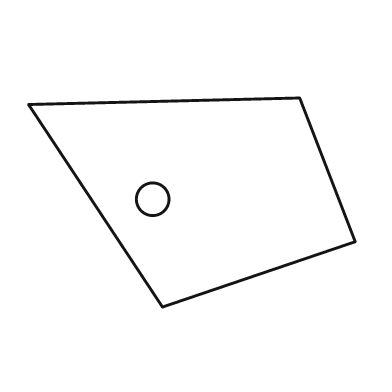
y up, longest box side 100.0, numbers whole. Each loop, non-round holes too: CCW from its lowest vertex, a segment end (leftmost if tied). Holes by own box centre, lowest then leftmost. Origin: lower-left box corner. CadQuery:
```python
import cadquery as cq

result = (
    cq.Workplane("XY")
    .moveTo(41.0, 0.0)
    .lineTo(100.0, 20.0)
    .lineTo(83.0, 64.0)
    .lineTo(0.0, 62.0)
    .close()
    .moveTo(38.0, 33.0)
    .circle(5.0)
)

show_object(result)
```